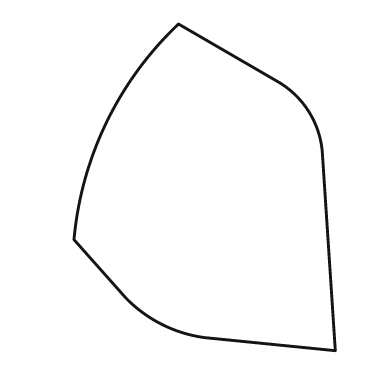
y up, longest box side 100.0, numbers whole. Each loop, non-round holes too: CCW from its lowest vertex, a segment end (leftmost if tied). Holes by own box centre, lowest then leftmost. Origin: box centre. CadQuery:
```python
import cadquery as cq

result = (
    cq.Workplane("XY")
    .moveTo(40.0, -50.0)
    .lineTo(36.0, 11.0)
    .threePointArc((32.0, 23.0), (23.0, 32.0))
    .lineTo(-8.0, 50.0)
    .threePointArc((-30.0, 20.0), (-40.0, -16.0))
    .lineTo(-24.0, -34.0)
    .threePointArc((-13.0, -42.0), (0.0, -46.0))
    .close()
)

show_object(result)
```